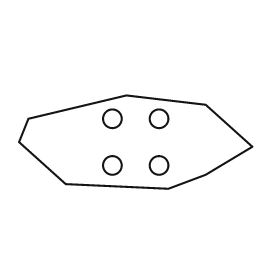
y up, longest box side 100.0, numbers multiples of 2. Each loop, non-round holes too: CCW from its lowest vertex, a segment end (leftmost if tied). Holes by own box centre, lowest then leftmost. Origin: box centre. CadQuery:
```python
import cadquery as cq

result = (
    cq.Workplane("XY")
    .moveTo(14.0, -20.0)
    .lineTo(30.0, -14.0)
    .lineTo(50.0, -2.0)
    .lineTo(30.0, 16.0)
    .lineTo(-4.0, 20.0)
    .lineTo(-46.0, 10.0)
    .lineTo(-50.0, 0.0)
    .lineTo(-30.0, -18.0)
    .close()
    .moveTo(-10.0, -10.0)
    .circle(4.0)
    .moveTo(10.0, -10.0)
    .circle(4.0)
    .moveTo(-10.0, 10.0)
    .circle(4.0)
    .moveTo(10.0, 10.0)
    .circle(4.0)
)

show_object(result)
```